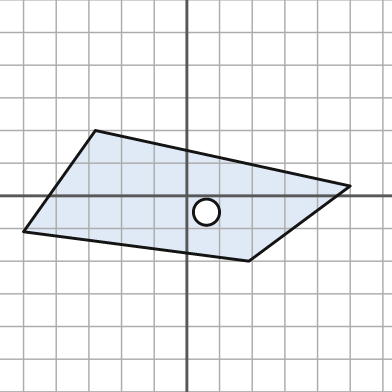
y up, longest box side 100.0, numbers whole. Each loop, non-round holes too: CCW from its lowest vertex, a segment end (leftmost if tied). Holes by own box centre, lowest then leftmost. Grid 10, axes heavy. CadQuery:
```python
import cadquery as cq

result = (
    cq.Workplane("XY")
    .moveTo(19.0, -20.0)
    .lineTo(50.0, 3.0)
    .lineTo(-28.0, 20.0)
    .lineTo(-50.0, -11.0)
    .close()
    .moveTo(6.0, -5.0)
    .circle(4.0)
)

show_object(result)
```